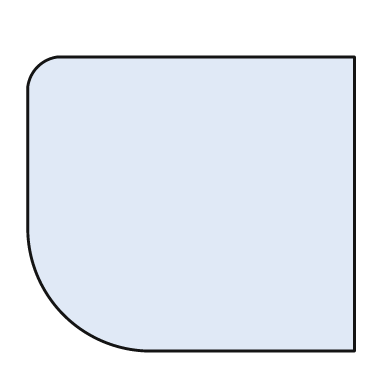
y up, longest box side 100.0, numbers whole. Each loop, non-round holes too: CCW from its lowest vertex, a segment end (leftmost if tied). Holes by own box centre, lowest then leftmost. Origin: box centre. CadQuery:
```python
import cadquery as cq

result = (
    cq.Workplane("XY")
    .moveTo(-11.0, -45.0)
    .lineTo(50.0, -45.0)
    .lineTo(50.0, 45.0)
    .lineTo(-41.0, 45.0)
    .threePointArc((-47.0, 42.0), (-50.0, 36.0))
    .lineTo(-50.0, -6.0)
    .threePointArc((-39.0, -34.0), (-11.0, -45.0))
    .close()
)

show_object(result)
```